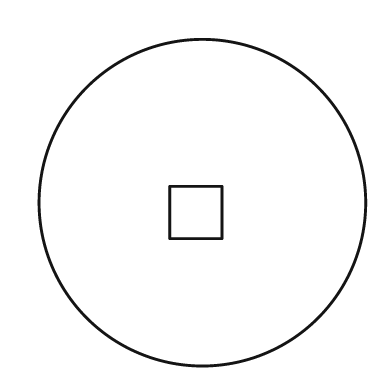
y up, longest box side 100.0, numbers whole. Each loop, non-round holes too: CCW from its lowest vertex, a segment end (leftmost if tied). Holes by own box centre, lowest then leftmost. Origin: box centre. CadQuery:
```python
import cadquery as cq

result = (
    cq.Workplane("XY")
    .moveTo(0.0, 0.0)
    .circle(50.0)
    .moveTo(-10.0, -11.0)
    .lineTo(6.0, -11.0)
    .lineTo(6.0, 5.0)
    .lineTo(-10.0, 5.0)
    .close()
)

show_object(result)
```